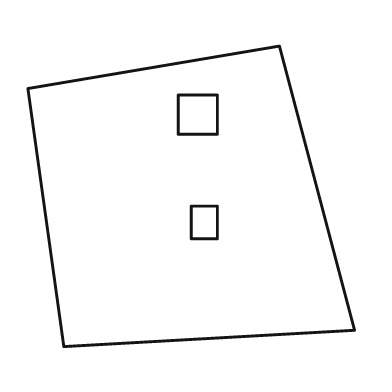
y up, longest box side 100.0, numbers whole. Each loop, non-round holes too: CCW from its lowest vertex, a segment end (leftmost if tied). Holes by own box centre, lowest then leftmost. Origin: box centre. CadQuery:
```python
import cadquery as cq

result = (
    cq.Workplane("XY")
    .moveTo(-39.0, -46.0)
    .lineTo(50.0, -41.0)
    .lineTo(27.0, 46.0)
    .lineTo(-50.0, 33.0)
    .close()
    .moveTo(0.0, -13.0)
    .lineTo(8.0, -13.0)
    .lineTo(8.0, -3.0)
    .lineTo(0.0, -3.0)
    .close()
    .moveTo(-4.0, 19.0)
    .lineTo(8.0, 19.0)
    .lineTo(8.0, 31.0)
    .lineTo(-4.0, 31.0)
    .close()
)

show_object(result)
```